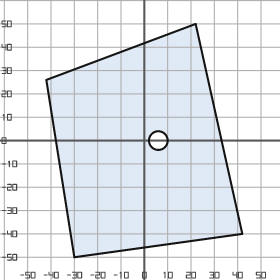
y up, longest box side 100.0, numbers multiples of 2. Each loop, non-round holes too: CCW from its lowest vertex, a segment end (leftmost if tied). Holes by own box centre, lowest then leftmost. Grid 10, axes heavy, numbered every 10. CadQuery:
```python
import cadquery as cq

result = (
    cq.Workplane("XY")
    .moveTo(-30.0, -50.0)
    .lineTo(42.0, -40.0)
    .lineTo(22.0, 50.0)
    .lineTo(-42.0, 26.0)
    .close()
    .moveTo(6.0, 0.0)
    .circle(4.0)
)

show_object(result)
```